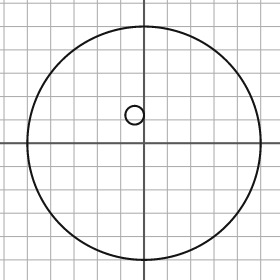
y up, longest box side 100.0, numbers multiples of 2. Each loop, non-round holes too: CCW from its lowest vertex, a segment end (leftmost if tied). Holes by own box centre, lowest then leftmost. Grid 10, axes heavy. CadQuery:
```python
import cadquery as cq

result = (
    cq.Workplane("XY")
    .moveTo(0.0, 0.0)
    .circle(50.0)
    .moveTo(-4.0, 12.0)
    .circle(4.0)
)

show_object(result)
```